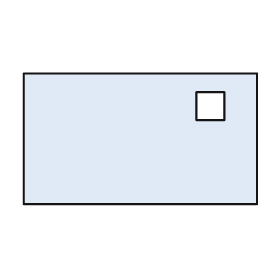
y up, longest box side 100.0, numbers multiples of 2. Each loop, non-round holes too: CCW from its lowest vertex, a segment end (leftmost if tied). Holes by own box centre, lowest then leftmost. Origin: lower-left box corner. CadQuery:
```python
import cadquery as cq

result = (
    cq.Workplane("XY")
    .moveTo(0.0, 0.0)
    .lineTo(100.0, 0.0)
    .lineTo(100.0, 56.0)
    .lineTo(0.0, 56.0)
    .close()
    .moveTo(74.0, 36.0)
    .lineTo(86.0, 36.0)
    .lineTo(86.0, 48.0)
    .lineTo(74.0, 48.0)
    .close()
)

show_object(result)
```